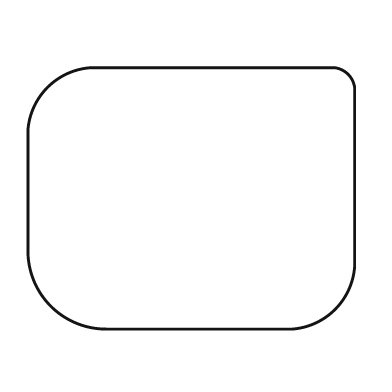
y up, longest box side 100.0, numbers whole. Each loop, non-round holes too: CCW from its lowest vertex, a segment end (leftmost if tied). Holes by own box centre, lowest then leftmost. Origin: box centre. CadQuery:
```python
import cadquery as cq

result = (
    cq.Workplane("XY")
    .moveTo(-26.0, -40.0)
    .lineTo(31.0, -40.0)
    .threePointArc((44.0, -34.0), (50.0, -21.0))
    .lineTo(50.0, 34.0)
    .threePointArc((48.0, 38.0), (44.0, 40.0))
    .lineTo(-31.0, 40.0)
    .threePointArc((-44.0, 34.0), (-50.0, 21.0))
    .lineTo(-50.0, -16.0)
    .threePointArc((-43.0, -33.0), (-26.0, -40.0))
    .close()
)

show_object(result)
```